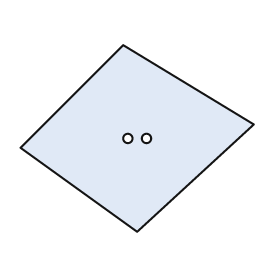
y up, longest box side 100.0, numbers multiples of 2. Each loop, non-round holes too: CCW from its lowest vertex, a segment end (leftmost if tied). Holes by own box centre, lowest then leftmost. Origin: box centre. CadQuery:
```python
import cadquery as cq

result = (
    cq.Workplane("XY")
    .moveTo(0.0, -40.0)
    .lineTo(50.0, 6.0)
    .lineTo(-6.0, 40.0)
    .lineTo(-50.0, -4.0)
    .close()
    .moveTo(-4.0, 0.0)
    .circle(2.0)
    .moveTo(4.0, 0.0)
    .circle(2.0)
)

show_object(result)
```